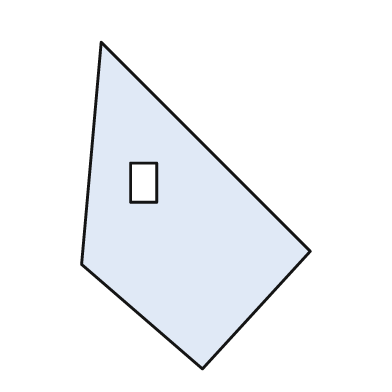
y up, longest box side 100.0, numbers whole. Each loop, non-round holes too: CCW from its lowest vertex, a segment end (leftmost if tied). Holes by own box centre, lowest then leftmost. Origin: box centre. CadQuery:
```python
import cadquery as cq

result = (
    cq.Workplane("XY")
    .moveTo(2.0, -50.0)
    .lineTo(35.0, -14.0)
    .lineTo(-29.0, 50.0)
    .lineTo(-35.0, -18.0)
    .close()
    .moveTo(-20.0, 1.0)
    .lineTo(-12.0, 1.0)
    .lineTo(-12.0, 13.0)
    .lineTo(-20.0, 13.0)
    .close()
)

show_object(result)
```